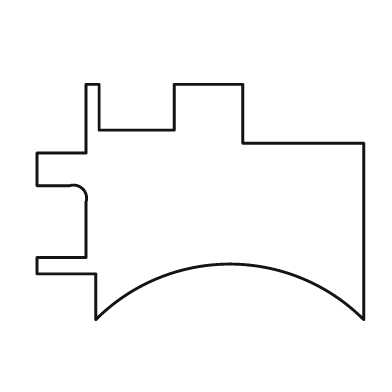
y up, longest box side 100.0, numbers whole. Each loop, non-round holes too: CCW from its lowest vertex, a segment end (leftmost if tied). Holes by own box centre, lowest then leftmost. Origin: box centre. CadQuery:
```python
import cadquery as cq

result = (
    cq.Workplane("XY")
    .moveTo(-32.0, -36.0)
    .threePointArc((9.0, -19.0), (50.0, -36.0))
    .lineTo(50.0, 18.0)
    .lineTo(13.0, 18.0)
    .lineTo(13.0, 36.0)
    .lineTo(-8.0, 36.0)
    .lineTo(-8.0, 22.0)
    .lineTo(-31.0, 22.0)
    .lineTo(-31.0, 36.0)
    .lineTo(-35.0, 36.0)
    .lineTo(-35.0, 15.0)
    .lineTo(-50.0, 15.0)
    .lineTo(-50.0, 5.0)
    .lineTo(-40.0, 5.0)
    .threePointArc((-36.0, 4.0), (-35.0, 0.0))
    .lineTo(-35.0, -17.0)
    .lineTo(-50.0, -17.0)
    .lineTo(-50.0, -22.0)
    .lineTo(-32.0, -22.0)
    .close()
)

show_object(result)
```